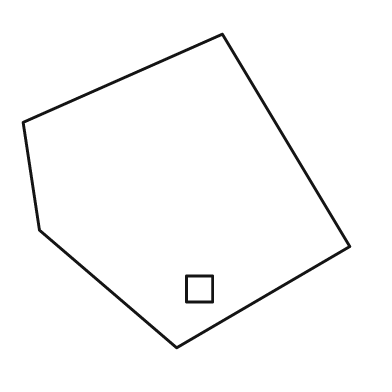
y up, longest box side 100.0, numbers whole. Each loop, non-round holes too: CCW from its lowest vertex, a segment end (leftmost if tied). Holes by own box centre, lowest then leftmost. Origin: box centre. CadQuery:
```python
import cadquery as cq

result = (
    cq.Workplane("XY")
    .moveTo(-3.0, -48.0)
    .lineTo(50.0, -17.0)
    .lineTo(11.0, 48.0)
    .lineTo(-50.0, 21.0)
    .lineTo(-45.0, -12.0)
    .close()
    .moveTo(0.0, -34.0)
    .lineTo(8.0, -34.0)
    .lineTo(8.0, -26.0)
    .lineTo(0.0, -26.0)
    .close()
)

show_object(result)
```